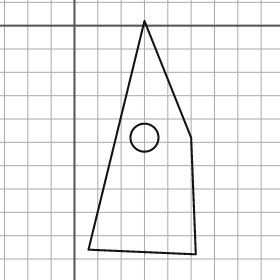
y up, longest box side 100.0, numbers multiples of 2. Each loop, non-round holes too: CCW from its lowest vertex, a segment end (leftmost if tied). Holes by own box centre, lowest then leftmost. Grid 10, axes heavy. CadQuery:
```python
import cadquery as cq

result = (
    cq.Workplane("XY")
    .moveTo(52.0, -98.0)
    .lineTo(50.0, -48.0)
    .lineTo(30.0, 2.0)
    .lineTo(6.0, -96.0)
    .close()
    .moveTo(30.0, -48.0)
    .circle(6.0)
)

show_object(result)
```